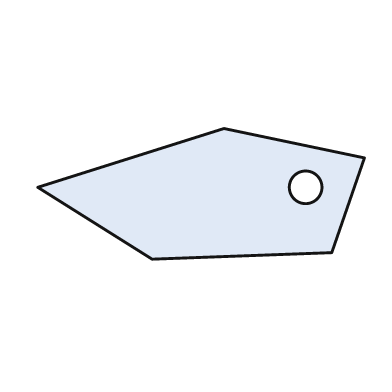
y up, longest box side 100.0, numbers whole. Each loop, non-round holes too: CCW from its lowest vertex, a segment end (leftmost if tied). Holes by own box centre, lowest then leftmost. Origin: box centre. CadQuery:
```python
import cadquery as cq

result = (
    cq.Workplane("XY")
    .moveTo(-15.0, -20.0)
    .lineTo(40.0, -18.0)
    .lineTo(50.0, 11.0)
    .lineTo(7.0, 20.0)
    .lineTo(-50.0, 2.0)
    .close()
    .moveTo(32.0, 2.0)
    .circle(5.0)
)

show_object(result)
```